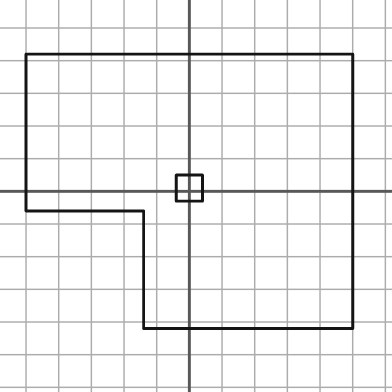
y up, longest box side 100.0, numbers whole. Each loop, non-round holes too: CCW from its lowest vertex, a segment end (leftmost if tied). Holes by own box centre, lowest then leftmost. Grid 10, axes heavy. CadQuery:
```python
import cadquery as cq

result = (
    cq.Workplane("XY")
    .moveTo(-14.0, -42.0)
    .lineTo(50.0, -42.0)
    .lineTo(50.0, 42.0)
    .lineTo(-50.0, 42.0)
    .lineTo(-50.0, -6.0)
    .lineTo(-14.0, -6.0)
    .close()
    .moveTo(-4.0, -3.0)
    .lineTo(4.0, -3.0)
    .lineTo(4.0, 5.0)
    .lineTo(-4.0, 5.0)
    .close()
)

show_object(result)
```